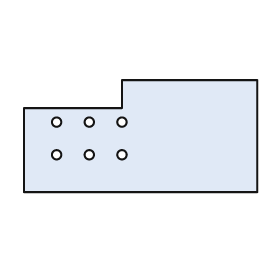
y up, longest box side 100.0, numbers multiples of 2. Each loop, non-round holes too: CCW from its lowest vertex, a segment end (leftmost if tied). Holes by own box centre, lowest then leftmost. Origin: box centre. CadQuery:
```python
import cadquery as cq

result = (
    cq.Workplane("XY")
    .moveTo(-50.0, -24.0)
    .lineTo(50.0, -24.0)
    .lineTo(50.0, 24.0)
    .lineTo(-8.0, 24.0)
    .lineTo(-8.0, 12.0)
    .lineTo(-50.0, 12.0)
    .close()
    .moveTo(-36.0, -8.0)
    .circle(2.0)
    .moveTo(-22.0, -8.0)
    .circle(2.0)
    .moveTo(-8.0, -8.0)
    .circle(2.0)
    .moveTo(-36.0, 6.0)
    .circle(2.0)
    .moveTo(-22.0, 6.0)
    .circle(2.0)
    .moveTo(-8.0, 6.0)
    .circle(2.0)
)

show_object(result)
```